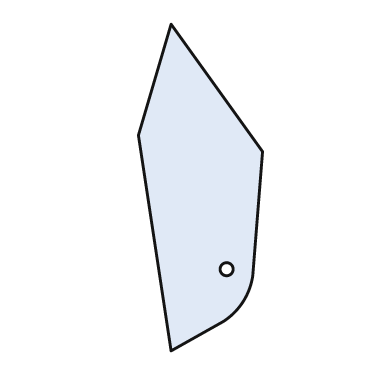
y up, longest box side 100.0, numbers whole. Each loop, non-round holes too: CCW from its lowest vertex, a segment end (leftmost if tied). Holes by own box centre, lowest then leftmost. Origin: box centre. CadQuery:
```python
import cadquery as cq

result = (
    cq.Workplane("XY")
    .moveTo(-9.0, -50.0)
    .lineTo(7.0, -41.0)
    .threePointArc((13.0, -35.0), (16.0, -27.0))
    .lineTo(19.0, 11.0)
    .lineTo(-9.0, 50.0)
    .lineTo(-19.0, 16.0)
    .close()
    .moveTo(8.0, -25.0)
    .circle(2.0)
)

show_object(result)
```